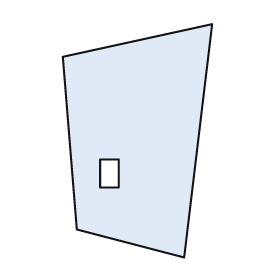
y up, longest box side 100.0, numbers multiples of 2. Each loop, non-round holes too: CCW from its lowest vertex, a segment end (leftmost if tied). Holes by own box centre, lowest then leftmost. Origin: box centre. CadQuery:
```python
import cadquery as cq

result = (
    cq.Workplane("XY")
    .moveTo(20.0, -50.0)
    .lineTo(32.0, 50.0)
    .lineTo(-32.0, 36.0)
    .lineTo(-26.0, -38.0)
    .close()
    .moveTo(-16.0, -20.0)
    .lineTo(-8.0, -20.0)
    .lineTo(-8.0, -8.0)
    .lineTo(-16.0, -8.0)
    .close()
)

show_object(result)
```